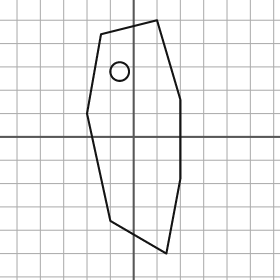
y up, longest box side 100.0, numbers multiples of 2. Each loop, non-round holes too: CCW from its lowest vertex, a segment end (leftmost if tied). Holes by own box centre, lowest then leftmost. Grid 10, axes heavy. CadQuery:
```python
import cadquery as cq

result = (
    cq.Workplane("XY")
    .moveTo(14.0, -50.0)
    .lineTo(20.0, -18.0)
    .lineTo(20.0, 16.0)
    .lineTo(10.0, 50.0)
    .lineTo(-14.0, 44.0)
    .lineTo(-20.0, 10.0)
    .lineTo(-10.0, -36.0)
    .close()
    .moveTo(-6.0, 28.0)
    .circle(4.0)
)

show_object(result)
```